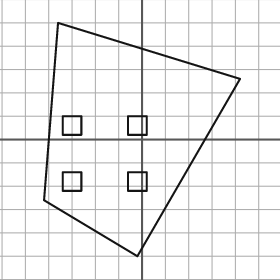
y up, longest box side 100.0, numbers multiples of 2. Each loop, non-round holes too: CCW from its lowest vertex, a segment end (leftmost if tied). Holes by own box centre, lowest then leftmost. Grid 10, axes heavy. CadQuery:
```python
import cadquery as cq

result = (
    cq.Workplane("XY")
    .moveTo(-2.0, -50.0)
    .lineTo(42.0, 26.0)
    .lineTo(-36.0, 50.0)
    .lineTo(-42.0, -26.0)
    .close()
    .moveTo(-34.0, -22.0)
    .lineTo(-26.0, -22.0)
    .lineTo(-26.0, -14.0)
    .lineTo(-34.0, -14.0)
    .close()
    .moveTo(-6.0, -22.0)
    .lineTo(2.0, -22.0)
    .lineTo(2.0, -14.0)
    .lineTo(-6.0, -14.0)
    .close()
    .moveTo(-34.0, 2.0)
    .lineTo(-26.0, 2.0)
    .lineTo(-26.0, 10.0)
    .lineTo(-34.0, 10.0)
    .close()
    .moveTo(-6.0, 2.0)
    .lineTo(2.0, 2.0)
    .lineTo(2.0, 10.0)
    .lineTo(-6.0, 10.0)
    .close()
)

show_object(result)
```